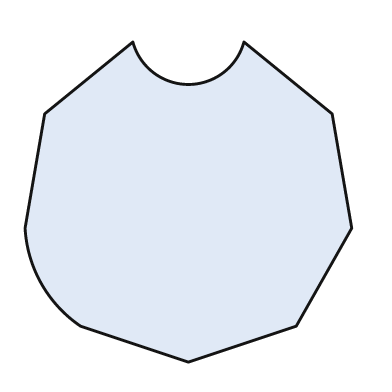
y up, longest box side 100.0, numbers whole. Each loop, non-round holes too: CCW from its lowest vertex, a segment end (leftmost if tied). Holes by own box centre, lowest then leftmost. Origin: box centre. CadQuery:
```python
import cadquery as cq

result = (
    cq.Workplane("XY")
    .moveTo(0.0, -49.0)
    .lineTo(33.0, -38.0)
    .lineTo(50.0, -8.0)
    .lineTo(44.0, 27.0)
    .lineTo(17.0, 49.0)
    .threePointArc((0.0, 36.0), (-17.0, 49.0))
    .lineTo(-44.0, 27.0)
    .lineTo(-50.0, -8.0)
    .threePointArc((-45.0, -25.0), (-33.0, -38.0))
    .close()
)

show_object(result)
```